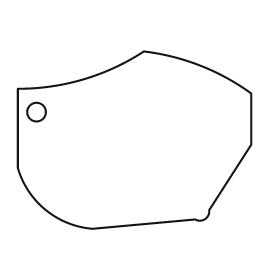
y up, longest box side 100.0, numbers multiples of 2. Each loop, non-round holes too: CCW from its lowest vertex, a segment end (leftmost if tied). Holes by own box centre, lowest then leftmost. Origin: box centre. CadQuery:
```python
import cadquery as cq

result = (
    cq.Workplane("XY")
    .moveTo(-18.0, -38.0)
    .lineTo(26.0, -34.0)
    .threePointArc((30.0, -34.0), (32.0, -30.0))
    .lineTo(50.0, -2.0)
    .lineTo(50.0, 20.0)
    .threePointArc((28.0, 32.0), (4.0, 38.0))
    .threePointArc((-22.0, 26.0), (-50.0, 22.0))
    .lineTo(-50.0, -12.0)
    .threePointArc((-38.0, -30.0), (-18.0, -38.0))
    .close()
    .moveTo(-42.0, 12.0)
    .circle(4.0)
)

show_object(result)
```